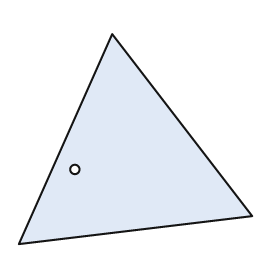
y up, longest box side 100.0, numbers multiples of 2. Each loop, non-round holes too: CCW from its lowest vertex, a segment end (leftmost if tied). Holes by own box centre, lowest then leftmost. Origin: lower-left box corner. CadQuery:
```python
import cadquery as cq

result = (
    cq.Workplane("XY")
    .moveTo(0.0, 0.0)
    .lineTo(100.0, 12.0)
    .lineTo(40.0, 90.0)
    .close()
    .moveTo(24.0, 32.0)
    .circle(2.0)
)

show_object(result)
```